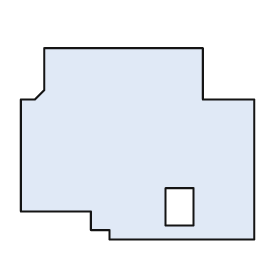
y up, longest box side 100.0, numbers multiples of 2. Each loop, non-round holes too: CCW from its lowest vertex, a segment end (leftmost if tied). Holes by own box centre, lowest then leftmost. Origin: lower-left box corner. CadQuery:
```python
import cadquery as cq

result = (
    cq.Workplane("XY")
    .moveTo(38.0, 0.0)
    .lineTo(100.0, 0.0)
    .lineTo(100.0, 60.0)
    .lineTo(78.0, 60.0)
    .lineTo(78.0, 82.0)
    .lineTo(10.0, 82.0)
    .lineTo(10.0, 64.0)
    .lineTo(6.0, 60.0)
    .lineTo(0.0, 60.0)
    .lineTo(0.0, 12.0)
    .lineTo(30.0, 12.0)
    .lineTo(30.0, 4.0)
    .lineTo(38.0, 4.0)
    .close()
    .moveTo(62.0, 6.0)
    .lineTo(74.0, 6.0)
    .lineTo(74.0, 22.0)
    .lineTo(62.0, 22.0)
    .close()
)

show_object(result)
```